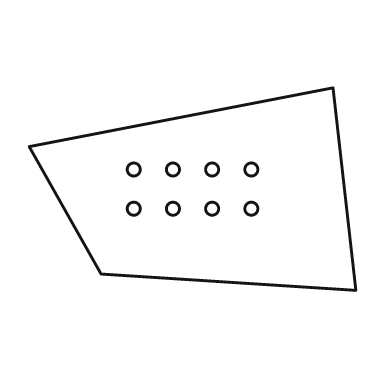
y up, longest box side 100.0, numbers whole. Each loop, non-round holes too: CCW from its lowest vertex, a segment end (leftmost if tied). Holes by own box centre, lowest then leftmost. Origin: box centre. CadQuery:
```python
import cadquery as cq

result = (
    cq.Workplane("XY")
    .moveTo(50.0, -31.0)
    .lineTo(43.0, 31.0)
    .lineTo(-50.0, 13.0)
    .lineTo(-28.0, -26.0)
    .close()
    .moveTo(-18.0, -6.0)
    .circle(2.0)
    .moveTo(-6.0, -6.0)
    .circle(2.0)
    .moveTo(6.0, -6.0)
    .circle(2.0)
    .moveTo(18.0, -6.0)
    .circle(2.0)
    .moveTo(-18.0, 6.0)
    .circle(2.0)
    .moveTo(-6.0, 6.0)
    .circle(2.0)
    .moveTo(6.0, 6.0)
    .circle(2.0)
    .moveTo(18.0, 6.0)
    .circle(2.0)
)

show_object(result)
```